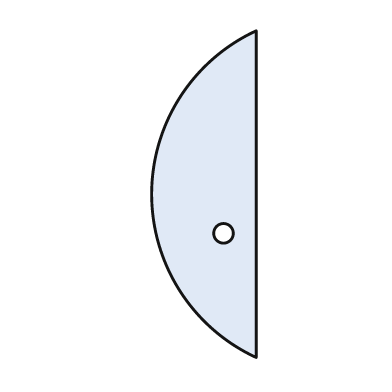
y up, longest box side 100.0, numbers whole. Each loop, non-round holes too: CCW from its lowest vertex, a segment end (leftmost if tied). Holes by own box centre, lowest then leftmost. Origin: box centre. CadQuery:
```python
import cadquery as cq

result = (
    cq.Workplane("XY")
    .moveTo(16.0, -50.0)
    .lineTo(16.0, 50.0)
    .threePointArc((-16.0, 0.0), (16.0, -50.0))
    .close()
    .moveTo(6.0, -12.0)
    .circle(3.0)
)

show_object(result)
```